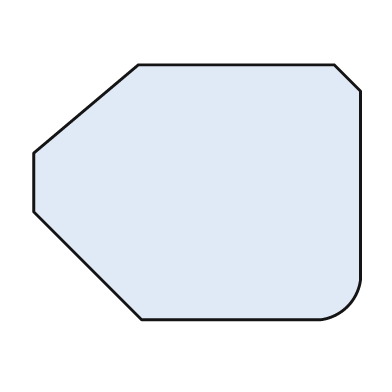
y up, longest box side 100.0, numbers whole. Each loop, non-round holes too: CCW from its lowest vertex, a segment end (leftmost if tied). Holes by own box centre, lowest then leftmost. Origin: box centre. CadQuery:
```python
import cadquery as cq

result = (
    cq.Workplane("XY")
    .moveTo(-17.0, -39.0)
    .lineTo(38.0, -39.0)
    .threePointArc((46.0, -35.0), (50.0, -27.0))
    .lineTo(50.0, 31.0)
    .lineTo(42.0, 39.0)
    .lineTo(-18.0, 39.0)
    .lineTo(-50.0, 12.0)
    .lineTo(-50.0, -6.0)
    .close()
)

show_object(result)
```